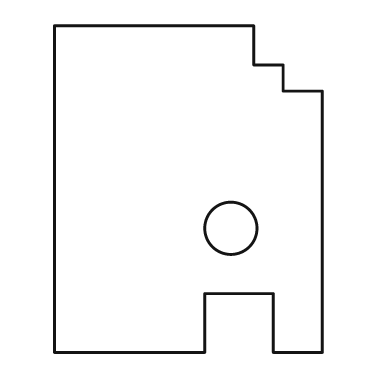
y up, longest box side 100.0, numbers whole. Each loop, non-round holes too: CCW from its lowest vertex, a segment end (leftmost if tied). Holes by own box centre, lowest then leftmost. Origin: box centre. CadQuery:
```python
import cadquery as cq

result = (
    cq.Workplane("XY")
    .moveTo(-41.0, -50.0)
    .lineTo(5.0, -50.0)
    .lineTo(5.0, -32.0)
    .lineTo(26.0, -32.0)
    .lineTo(26.0, -50.0)
    .lineTo(41.0, -50.0)
    .lineTo(41.0, 30.0)
    .lineTo(29.0, 30.0)
    .lineTo(29.0, 38.0)
    .lineTo(20.0, 38.0)
    .lineTo(20.0, 50.0)
    .lineTo(-41.0, 50.0)
    .close()
    .moveTo(13.0, -12.0)
    .circle(8.0)
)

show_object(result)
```